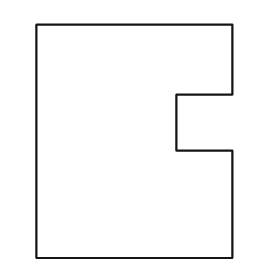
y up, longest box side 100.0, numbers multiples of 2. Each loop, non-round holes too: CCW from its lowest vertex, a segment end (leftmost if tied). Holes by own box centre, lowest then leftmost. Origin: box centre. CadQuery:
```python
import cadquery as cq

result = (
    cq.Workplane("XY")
    .moveTo(-42.0, -50.0)
    .lineTo(42.0, -50.0)
    .lineTo(42.0, -4.0)
    .lineTo(18.0, -4.0)
    .lineTo(18.0, 20.0)
    .lineTo(42.0, 20.0)
    .lineTo(42.0, 50.0)
    .lineTo(-42.0, 50.0)
    .close()
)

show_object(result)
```